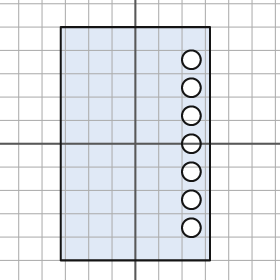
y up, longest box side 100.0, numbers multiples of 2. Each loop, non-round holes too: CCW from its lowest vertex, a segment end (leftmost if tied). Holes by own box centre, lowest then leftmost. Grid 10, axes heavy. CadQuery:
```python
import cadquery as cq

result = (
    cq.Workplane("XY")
    .moveTo(-32.0, -50.0)
    .lineTo(32.0, -50.0)
    .lineTo(32.0, 50.0)
    .lineTo(-32.0, 50.0)
    .close()
    .moveTo(24.0, -36.0)
    .circle(4.0)
    .moveTo(24.0, -24.0)
    .circle(4.0)
    .moveTo(24.0, -12.0)
    .circle(4.0)
    .moveTo(24.0, 0.0)
    .circle(4.0)
    .moveTo(24.0, 12.0)
    .circle(4.0)
    .moveTo(24.0, 24.0)
    .circle(4.0)
    .moveTo(24.0, 36.0)
    .circle(4.0)
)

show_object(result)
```